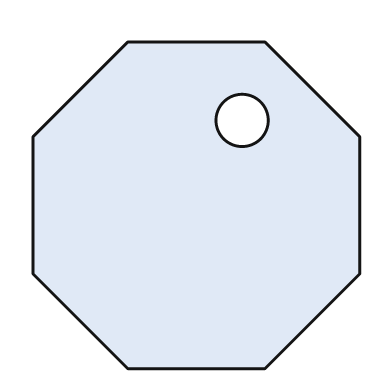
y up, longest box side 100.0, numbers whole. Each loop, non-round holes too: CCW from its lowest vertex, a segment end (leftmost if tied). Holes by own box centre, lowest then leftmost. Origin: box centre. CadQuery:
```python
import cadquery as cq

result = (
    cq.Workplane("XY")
    .moveTo(-21.0, -50.0)
    .lineTo(21.0, -50.0)
    .lineTo(50.0, -21.0)
    .lineTo(50.0, 21.0)
    .lineTo(21.0, 50.0)
    .lineTo(-21.0, 50.0)
    .lineTo(-50.0, 21.0)
    .lineTo(-50.0, -21.0)
    .close()
    .moveTo(14.0, 26.0)
    .circle(8.0)
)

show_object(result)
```